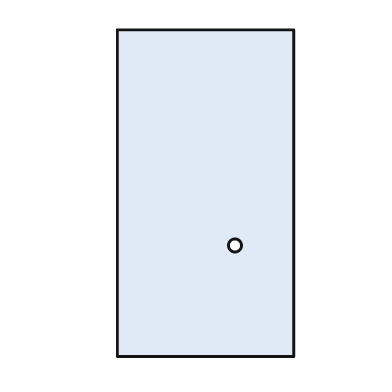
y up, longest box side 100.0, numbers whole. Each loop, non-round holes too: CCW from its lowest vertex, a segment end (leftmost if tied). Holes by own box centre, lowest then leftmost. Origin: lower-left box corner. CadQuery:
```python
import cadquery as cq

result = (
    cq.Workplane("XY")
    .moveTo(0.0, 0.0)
    .lineTo(54.0, 0.0)
    .lineTo(54.0, 100.0)
    .lineTo(0.0, 100.0)
    .close()
    .moveTo(36.0, 34.0)
    .circle(2.0)
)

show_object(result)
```